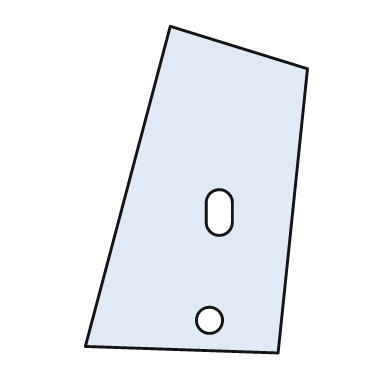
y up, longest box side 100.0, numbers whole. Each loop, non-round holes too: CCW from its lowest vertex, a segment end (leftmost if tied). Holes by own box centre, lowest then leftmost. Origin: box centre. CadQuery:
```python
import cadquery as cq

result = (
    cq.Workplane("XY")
    .moveTo(25.0, -50.0)
    .lineTo(34.0, 37.0)
    .lineTo(-8.0, 50.0)
    .lineTo(-34.0, -48.0)
    .close()
    .moveTo(4.0, -40.0)
    .circle(4.0)
    .moveTo(3.0, -10.0)
    .threePointArc((7.0, -14.0), (11.0, -10.0))
    .lineTo(11.0, -4.0)
    .threePointArc((7.0, 0.0), (3.0, -4.0))
    .close()
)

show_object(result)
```